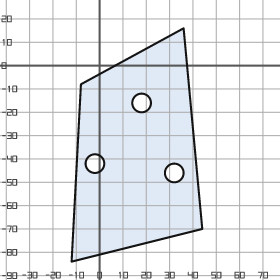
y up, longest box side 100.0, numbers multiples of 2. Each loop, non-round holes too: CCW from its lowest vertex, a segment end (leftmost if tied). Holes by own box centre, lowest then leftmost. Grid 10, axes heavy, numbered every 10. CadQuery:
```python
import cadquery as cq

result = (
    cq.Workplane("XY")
    .moveTo(-12.0, -84.0)
    .lineTo(44.0, -70.0)
    .lineTo(36.0, 16.0)
    .lineTo(-8.0, -8.0)
    .close()
    .moveTo(32.0, -46.0)
    .circle(4.0)
    .moveTo(-2.0, -42.0)
    .circle(4.0)
    .moveTo(18.0, -16.0)
    .circle(4.0)
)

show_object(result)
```